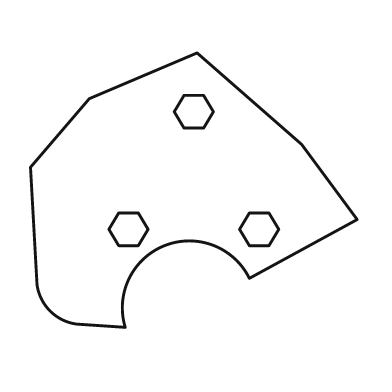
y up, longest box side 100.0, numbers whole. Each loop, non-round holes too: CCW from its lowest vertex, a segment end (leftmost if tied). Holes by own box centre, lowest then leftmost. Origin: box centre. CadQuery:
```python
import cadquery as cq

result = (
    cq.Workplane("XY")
    .moveTo(-21.0, -42.0)
    .threePointArc((-9.0, -17.0), (17.0, -27.0))
    .lineTo(50.0, -9.0)
    .lineTo(33.0, 14.0)
    .lineTo(1.0, 42.0)
    .lineTo(-32.0, 28.0)
    .lineTo(-50.0, 7.0)
    .lineTo(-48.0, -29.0)
    .threePointArc((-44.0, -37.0), (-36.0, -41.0))
    .close()
    .moveTo(-23.0, -17.0)
    .lineTo(-17.0, -17.0)
    .lineTo(-14.0, -12.0)
    .lineTo(-17.0, -7.0)
    .lineTo(-23.0, -7.0)
    .lineTo(-26.0, -12.0)
    .close()
    .moveTo(17.0, -17.0)
    .lineTo(23.0, -17.0)
    .lineTo(26.0, -12.0)
    .lineTo(23.0, -7.0)
    .lineTo(17.0, -7.0)
    .lineTo(14.0, -12.0)
    .close()
    .moveTo(-3.0, 19.0)
    .lineTo(3.0, 19.0)
    .lineTo(6.0, 24.0)
    .lineTo(3.0, 29.0)
    .lineTo(-3.0, 29.0)
    .lineTo(-6.0, 24.0)
    .close()
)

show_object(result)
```